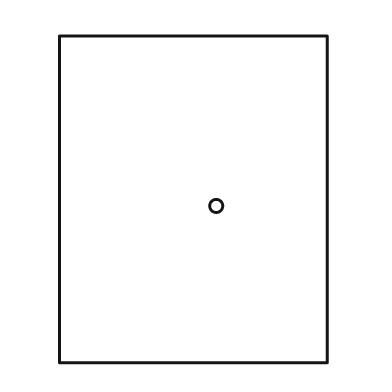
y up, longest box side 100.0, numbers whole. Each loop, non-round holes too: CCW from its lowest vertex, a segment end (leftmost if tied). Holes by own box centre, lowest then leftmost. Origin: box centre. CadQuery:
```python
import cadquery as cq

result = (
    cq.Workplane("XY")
    .moveTo(-41.0, -50.0)
    .lineTo(41.0, -50.0)
    .lineTo(41.0, 50.0)
    .lineTo(-41.0, 50.0)
    .close()
    .moveTo(7.0, -2.0)
    .circle(2.0)
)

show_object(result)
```